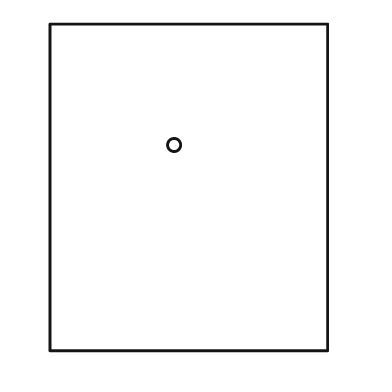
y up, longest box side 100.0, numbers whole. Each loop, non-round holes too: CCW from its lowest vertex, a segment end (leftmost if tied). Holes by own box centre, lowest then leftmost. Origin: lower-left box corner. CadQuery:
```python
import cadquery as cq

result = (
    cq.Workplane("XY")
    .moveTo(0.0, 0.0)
    .lineTo(85.0, 0.0)
    .lineTo(85.0, 100.0)
    .lineTo(0.0, 100.0)
    .close()
    .moveTo(38.0, 63.0)
    .circle(2.0)
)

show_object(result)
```